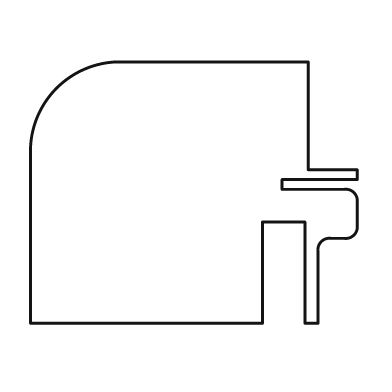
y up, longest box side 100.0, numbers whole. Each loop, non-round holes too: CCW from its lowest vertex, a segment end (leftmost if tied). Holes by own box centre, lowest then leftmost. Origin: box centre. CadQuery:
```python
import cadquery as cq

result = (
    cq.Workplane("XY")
    .moveTo(-50.0, -40.0)
    .lineTo(21.0, -40.0)
    .lineTo(21.0, -9.0)
    .lineTo(34.0, -9.0)
    .lineTo(34.0, -40.0)
    .lineTo(38.0, -40.0)
    .lineTo(38.0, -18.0)
    .threePointArc((39.0, -15.0), (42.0, -14.0))
    .lineTo(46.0, -14.0)
    .threePointArc((49.0, -13.0), (50.0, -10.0))
    .lineTo(50.0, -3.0)
    .threePointArc((49.0, 0.0), (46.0, 1.0))
    .lineTo(27.0, 1.0)
    .lineTo(27.0, 4.0)
    .lineTo(50.0, 4.0)
    .lineTo(50.0, 7.0)
    .lineTo(35.0, 7.0)
    .lineTo(35.0, 40.0)
    .lineTo(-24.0, 40.0)
    .threePointArc((-42.0, 32.0), (-50.0, 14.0))
    .close()
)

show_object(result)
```